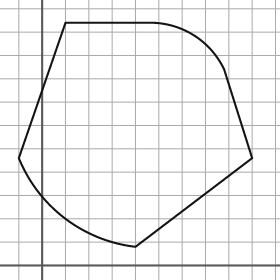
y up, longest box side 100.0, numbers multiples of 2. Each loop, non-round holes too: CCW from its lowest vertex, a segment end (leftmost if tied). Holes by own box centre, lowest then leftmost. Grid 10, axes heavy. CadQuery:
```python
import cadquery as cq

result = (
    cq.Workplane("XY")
    .moveTo(40.0, 8.0)
    .lineTo(90.0, 46.0)
    .lineTo(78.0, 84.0)
    .threePointArc((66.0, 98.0), (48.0, 104.0))
    .lineTo(10.0, 104.0)
    .lineTo(-10.0, 46.0)
    .threePointArc((10.0, 20.0), (40.0, 8.0))
    .close()
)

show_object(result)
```